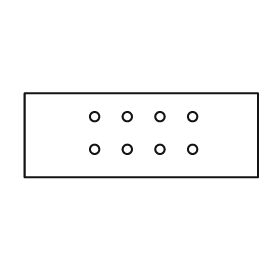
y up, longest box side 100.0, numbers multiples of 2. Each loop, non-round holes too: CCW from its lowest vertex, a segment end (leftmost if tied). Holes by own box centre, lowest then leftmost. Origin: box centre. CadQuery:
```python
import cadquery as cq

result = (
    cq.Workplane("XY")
    .moveTo(-50.0, -18.0)
    .lineTo(50.0, -18.0)
    .lineTo(50.0, 18.0)
    .lineTo(-50.0, 18.0)
    .close()
    .moveTo(-20.0, -6.0)
    .circle(2.0)
    .moveTo(-6.0, -6.0)
    .circle(2.0)
    .moveTo(8.0, -6.0)
    .circle(2.0)
    .moveTo(22.0, -6.0)
    .circle(2.0)
    .moveTo(-20.0, 8.0)
    .circle(2.0)
    .moveTo(-6.0, 8.0)
    .circle(2.0)
    .moveTo(8.0, 8.0)
    .circle(2.0)
    .moveTo(22.0, 8.0)
    .circle(2.0)
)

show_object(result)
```